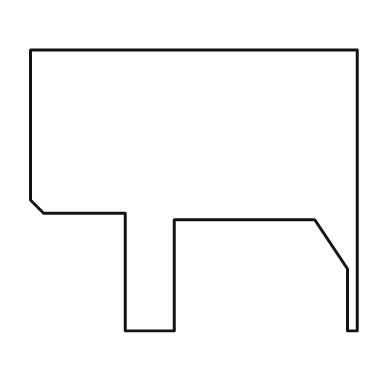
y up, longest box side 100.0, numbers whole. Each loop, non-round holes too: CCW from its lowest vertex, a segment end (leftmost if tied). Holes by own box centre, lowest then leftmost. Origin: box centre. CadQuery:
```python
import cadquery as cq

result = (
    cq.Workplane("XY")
    .moveTo(-21.0, -43.0)
    .lineTo(-6.0, -43.0)
    .lineTo(-6.0, -9.0)
    .lineTo(37.0, -9.0)
    .lineTo(47.0, -24.0)
    .lineTo(47.0, -43.0)
    .lineTo(50.0, -43.0)
    .lineTo(50.0, 43.0)
    .lineTo(-50.0, 43.0)
    .lineTo(-50.0, -3.0)
    .lineTo(-46.0, -7.0)
    .lineTo(-21.0, -7.0)
    .close()
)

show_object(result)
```